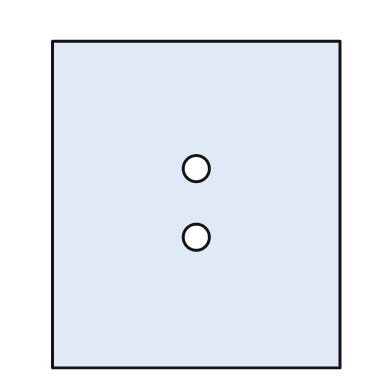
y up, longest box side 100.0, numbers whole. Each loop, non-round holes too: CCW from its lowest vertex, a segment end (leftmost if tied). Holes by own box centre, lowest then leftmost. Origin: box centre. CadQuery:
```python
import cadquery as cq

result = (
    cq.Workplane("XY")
    .moveTo(-44.0, -50.0)
    .lineTo(44.0, -50.0)
    .lineTo(44.0, 50.0)
    .lineTo(-44.0, 50.0)
    .close()
    .moveTo(0.0, -10.0)
    .circle(4.0)
    .moveTo(0.0, 11.0)
    .circle(4.0)
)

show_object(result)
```